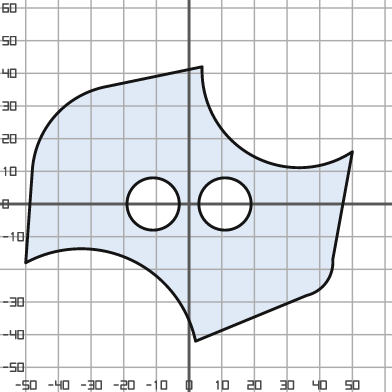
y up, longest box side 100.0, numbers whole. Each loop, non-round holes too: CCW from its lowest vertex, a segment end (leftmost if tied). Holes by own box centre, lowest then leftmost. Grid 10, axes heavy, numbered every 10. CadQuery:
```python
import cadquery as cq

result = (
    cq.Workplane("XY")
    .moveTo(2.0, -42.0)
    .lineTo(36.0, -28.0)
    .threePointArc((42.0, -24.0), (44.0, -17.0))
    .lineTo(50.0, 16.0)
    .threePointArc((19.0, 15.0), (4.0, 42.0))
    .lineTo(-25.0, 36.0)
    .threePointArc((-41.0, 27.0), (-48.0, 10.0))
    .lineTo(-50.0, -18.0)
    .threePointArc((-18.0, -17.0), (2.0, -42.0))
    .close()
    .moveTo(-11.0, 0.0)
    .circle(8.0)
    .moveTo(11.0, 0.0)
    .circle(8.0)
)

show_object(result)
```